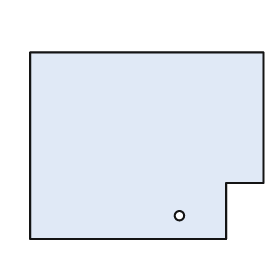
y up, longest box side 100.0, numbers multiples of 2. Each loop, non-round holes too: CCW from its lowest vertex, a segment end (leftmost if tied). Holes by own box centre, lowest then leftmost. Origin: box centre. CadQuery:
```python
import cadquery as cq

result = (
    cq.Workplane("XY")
    .moveTo(-50.0, -40.0)
    .lineTo(34.0, -40.0)
    .lineTo(34.0, -16.0)
    .lineTo(50.0, -16.0)
    .lineTo(50.0, 40.0)
    .lineTo(-50.0, 40.0)
    .close()
    .moveTo(14.0, -30.0)
    .circle(2.0)
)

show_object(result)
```